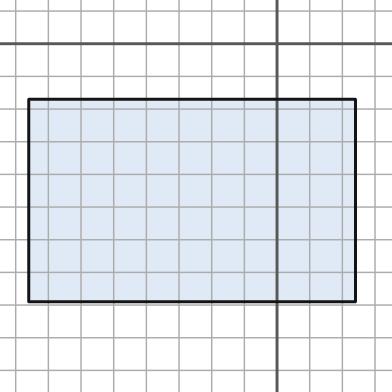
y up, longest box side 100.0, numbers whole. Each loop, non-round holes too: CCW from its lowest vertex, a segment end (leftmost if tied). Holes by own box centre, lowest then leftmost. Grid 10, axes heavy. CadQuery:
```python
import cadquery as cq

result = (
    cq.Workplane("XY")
    .moveTo(-76.0, -79.0)
    .lineTo(24.0, -79.0)
    .lineTo(24.0, -17.0)
    .lineTo(-76.0, -17.0)
    .close()
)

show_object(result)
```